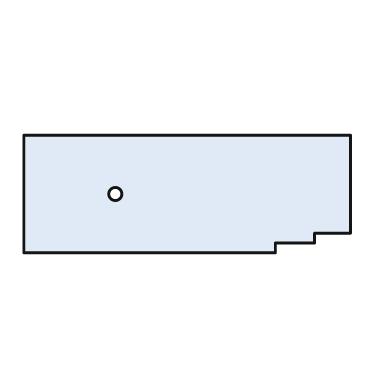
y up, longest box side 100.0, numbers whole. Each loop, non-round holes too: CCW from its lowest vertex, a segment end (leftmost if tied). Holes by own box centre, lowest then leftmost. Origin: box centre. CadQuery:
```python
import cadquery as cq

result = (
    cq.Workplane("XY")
    .moveTo(-50.0, -18.0)
    .lineTo(27.0, -18.0)
    .lineTo(27.0, -15.0)
    .lineTo(39.0, -15.0)
    .lineTo(39.0, -12.0)
    .lineTo(50.0, -12.0)
    .lineTo(50.0, 18.0)
    .lineTo(-50.0, 18.0)
    .close()
    .moveTo(-22.0, 0.0)
    .circle(2.0)
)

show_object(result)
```